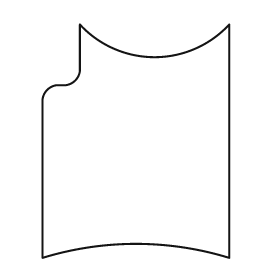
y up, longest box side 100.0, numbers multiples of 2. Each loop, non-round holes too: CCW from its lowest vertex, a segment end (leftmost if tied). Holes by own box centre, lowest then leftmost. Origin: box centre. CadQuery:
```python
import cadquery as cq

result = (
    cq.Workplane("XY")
    .moveTo(-40.0, -50.0)
    .threePointArc((0.0, -44.0), (40.0, -50.0))
    .lineTo(40.0, 50.0)
    .threePointArc((8.0, 36.0), (-24.0, 50.0))
    .lineTo(-24.0, 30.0)
    .threePointArc((-26.0, 26.0), (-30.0, 24.0))
    .lineTo(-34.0, 24.0)
    .threePointArc((-38.0, 22.0), (-40.0, 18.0))
    .close()
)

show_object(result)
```